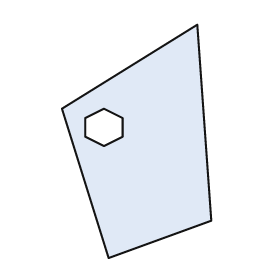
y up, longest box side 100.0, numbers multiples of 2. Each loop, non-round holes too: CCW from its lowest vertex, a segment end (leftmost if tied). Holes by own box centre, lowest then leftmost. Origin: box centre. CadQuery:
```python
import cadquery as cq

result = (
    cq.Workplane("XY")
    .moveTo(-12.0, -50.0)
    .lineTo(32.0, -34.0)
    .lineTo(26.0, 50.0)
    .lineTo(-32.0, 14.0)
    .close()
    .moveTo(-14.0, -2.0)
    .lineTo(-6.0, 2.0)
    .lineTo(-6.0, 10.0)
    .lineTo(-14.0, 14.0)
    .lineTo(-22.0, 10.0)
    .lineTo(-22.0, 2.0)
    .close()
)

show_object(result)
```